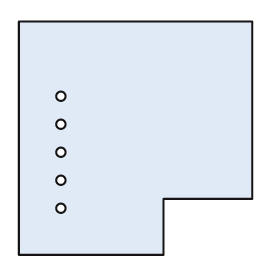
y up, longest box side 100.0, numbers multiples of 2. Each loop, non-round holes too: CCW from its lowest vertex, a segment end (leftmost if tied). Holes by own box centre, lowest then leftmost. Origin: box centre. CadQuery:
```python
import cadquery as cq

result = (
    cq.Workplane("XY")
    .moveTo(-50.0, -50.0)
    .lineTo(12.0, -50.0)
    .lineTo(12.0, -26.0)
    .lineTo(50.0, -26.0)
    .lineTo(50.0, 50.0)
    .lineTo(-50.0, 50.0)
    .close()
    .moveTo(-32.0, -30.0)
    .circle(2.0)
    .moveTo(-32.0, -18.0)
    .circle(2.0)
    .moveTo(-32.0, -6.0)
    .circle(2.0)
    .moveTo(-32.0, 6.0)
    .circle(2.0)
    .moveTo(-32.0, 18.0)
    .circle(2.0)
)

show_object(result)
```